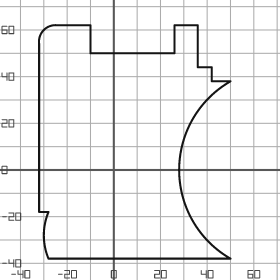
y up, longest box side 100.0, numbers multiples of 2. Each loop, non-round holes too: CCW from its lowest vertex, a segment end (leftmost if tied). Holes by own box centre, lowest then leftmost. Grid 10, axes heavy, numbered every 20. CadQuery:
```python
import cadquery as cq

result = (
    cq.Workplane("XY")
    .moveTo(-28.0, -38.0)
    .lineTo(50.0, -38.0)
    .threePointArc((28.0, 0.0), (50.0, 38.0))
    .lineTo(42.0, 38.0)
    .lineTo(42.0, 44.0)
    .lineTo(36.0, 44.0)
    .lineTo(36.0, 62.0)
    .lineTo(26.0, 62.0)
    .lineTo(26.0, 50.0)
    .lineTo(-10.0, 50.0)
    .lineTo(-10.0, 62.0)
    .lineTo(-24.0, 62.0)
    .threePointArc((-30.0, 60.0), (-32.0, 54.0))
    .lineTo(-32.0, -18.0)
    .lineTo(-28.0, -18.0)
    .threePointArc((-30.0, -28.0), (-28.0, -38.0))
    .close()
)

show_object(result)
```